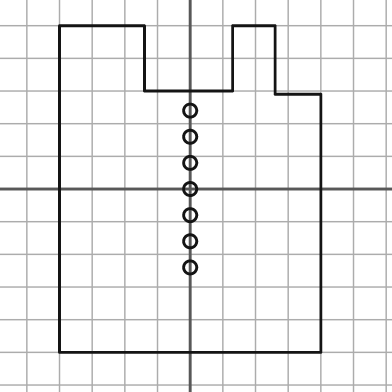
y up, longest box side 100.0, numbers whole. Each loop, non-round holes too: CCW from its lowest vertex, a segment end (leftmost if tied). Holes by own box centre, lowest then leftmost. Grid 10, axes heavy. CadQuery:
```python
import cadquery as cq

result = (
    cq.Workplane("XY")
    .moveTo(-40.0, -50.0)
    .lineTo(40.0, -50.0)
    .lineTo(40.0, 29.0)
    .lineTo(26.0, 29.0)
    .lineTo(26.0, 50.0)
    .lineTo(13.0, 50.0)
    .lineTo(13.0, 30.0)
    .lineTo(-14.0, 30.0)
    .lineTo(-14.0, 50.0)
    .lineTo(-40.0, 50.0)
    .close()
    .moveTo(0.0, -24.0)
    .circle(2.0)
    .moveTo(0.0, -16.0)
    .circle(2.0)
    .moveTo(0.0, -8.0)
    .circle(2.0)
    .moveTo(0.0, 0.0)
    .circle(2.0)
    .moveTo(0.0, 8.0)
    .circle(2.0)
    .moveTo(0.0, 16.0)
    .circle(2.0)
    .moveTo(0.0, 24.0)
    .circle(2.0)
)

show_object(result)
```